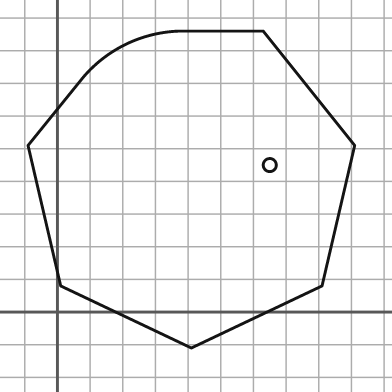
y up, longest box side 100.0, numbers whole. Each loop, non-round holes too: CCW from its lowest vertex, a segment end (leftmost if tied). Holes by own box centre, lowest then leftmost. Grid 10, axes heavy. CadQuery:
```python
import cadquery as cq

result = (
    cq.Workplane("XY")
    .moveTo(41.0, -11.0)
    .lineTo(81.0, 8.0)
    .lineTo(91.0, 51.0)
    .lineTo(63.0, 86.0)
    .lineTo(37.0, 86.0)
    .threePointArc((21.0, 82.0), (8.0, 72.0))
    .lineTo(-9.0, 51.0)
    .lineTo(1.0, 8.0)
    .close()
    .moveTo(65.0, 45.0)
    .circle(2.0)
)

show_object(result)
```